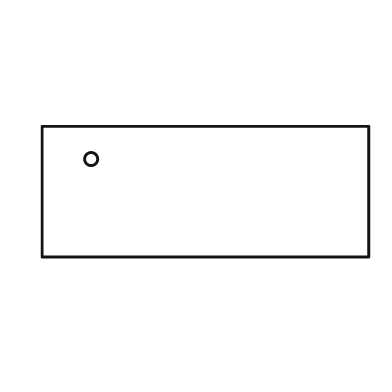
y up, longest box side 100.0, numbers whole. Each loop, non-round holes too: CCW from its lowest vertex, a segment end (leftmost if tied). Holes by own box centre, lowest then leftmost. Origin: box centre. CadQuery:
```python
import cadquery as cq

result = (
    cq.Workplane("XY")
    .moveTo(-50.0, -20.0)
    .lineTo(50.0, -20.0)
    .lineTo(50.0, 20.0)
    .lineTo(-50.0, 20.0)
    .close()
    .moveTo(-35.0, 10.0)
    .circle(2.0)
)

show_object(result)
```